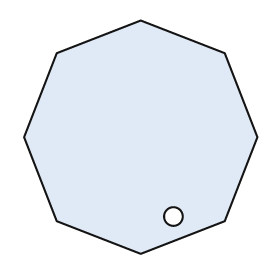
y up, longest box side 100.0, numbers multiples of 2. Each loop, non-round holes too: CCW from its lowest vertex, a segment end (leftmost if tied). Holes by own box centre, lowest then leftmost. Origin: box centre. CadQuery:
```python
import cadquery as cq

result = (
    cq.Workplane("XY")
    .moveTo(0.0, -50.0)
    .lineTo(36.0, -36.0)
    .lineTo(50.0, 0.0)
    .lineTo(36.0, 36.0)
    .lineTo(0.0, 50.0)
    .lineTo(-36.0, 36.0)
    .lineTo(-50.0, 0.0)
    .lineTo(-36.0, -36.0)
    .close()
    .moveTo(14.0, -34.0)
    .circle(4.0)
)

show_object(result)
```